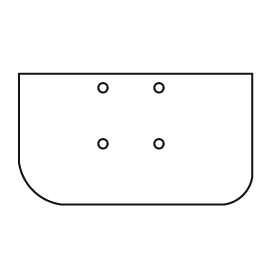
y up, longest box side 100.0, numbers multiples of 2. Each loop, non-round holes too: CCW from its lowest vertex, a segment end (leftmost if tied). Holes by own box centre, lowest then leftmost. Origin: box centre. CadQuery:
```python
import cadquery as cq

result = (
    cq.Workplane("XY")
    .moveTo(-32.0, -28.0)
    .lineTo(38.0, -28.0)
    .threePointArc((46.0, -24.0), (50.0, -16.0))
    .lineTo(50.0, 28.0)
    .lineTo(-50.0, 28.0)
    .lineTo(-50.0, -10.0)
    .threePointArc((-44.0, -22.0), (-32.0, -28.0))
    .close()
    .moveTo(-14.0, -2.0)
    .circle(2.0)
    .moveTo(10.0, -2.0)
    .circle(2.0)
    .moveTo(-14.0, 22.0)
    .circle(2.0)
    .moveTo(10.0, 22.0)
    .circle(2.0)
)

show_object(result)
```